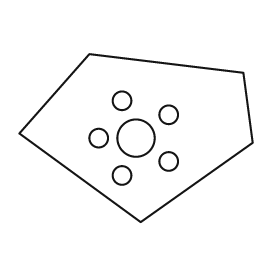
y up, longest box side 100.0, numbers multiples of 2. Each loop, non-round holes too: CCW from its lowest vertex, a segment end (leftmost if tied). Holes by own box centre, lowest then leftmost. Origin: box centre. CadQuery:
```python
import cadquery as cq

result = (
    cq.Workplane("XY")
    .moveTo(2.0, -36.0)
    .lineTo(50.0, -2.0)
    .lineTo(46.0, 28.0)
    .lineTo(-20.0, 36.0)
    .lineTo(-50.0, 2.0)
    .close()
    .moveTo(-6.0, -16.0)
    .circle(4.0)
    .moveTo(14.0, -10.0)
    .circle(4.0)
    .moveTo(-16.0, 0.0)
    .circle(4.0)
    .moveTo(0.0, 0.0)
    .circle(8.0)
    .moveTo(14.0, 10.0)
    .circle(4.0)
    .moveTo(-6.0, 16.0)
    .circle(4.0)
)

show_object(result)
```